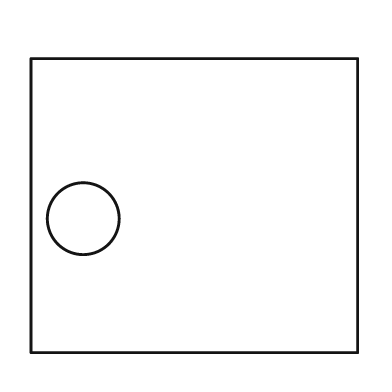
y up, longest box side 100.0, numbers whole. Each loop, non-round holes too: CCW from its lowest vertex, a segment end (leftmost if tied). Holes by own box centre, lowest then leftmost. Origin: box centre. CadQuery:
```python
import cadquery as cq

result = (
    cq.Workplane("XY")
    .moveTo(-50.0, -45.0)
    .lineTo(50.0, -45.0)
    .lineTo(50.0, 45.0)
    .lineTo(-50.0, 45.0)
    .close()
    .moveTo(-34.0, -4.0)
    .circle(11.0)
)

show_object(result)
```